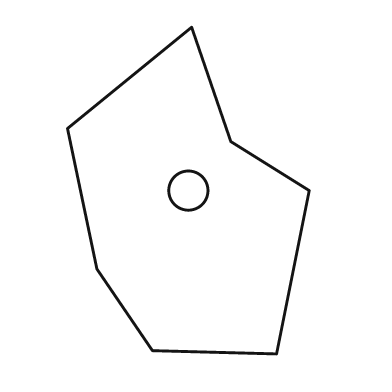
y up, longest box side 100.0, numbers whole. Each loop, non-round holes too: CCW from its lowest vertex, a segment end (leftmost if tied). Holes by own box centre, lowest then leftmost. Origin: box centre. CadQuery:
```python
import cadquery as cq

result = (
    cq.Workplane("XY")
    .moveTo(27.0, -50.0)
    .lineTo(37.0, 0.0)
    .lineTo(13.0, 15.0)
    .lineTo(1.0, 50.0)
    .lineTo(-37.0, 19.0)
    .lineTo(-28.0, -24.0)
    .lineTo(-11.0, -49.0)
    .close()
    .moveTo(0.0, 0.0)
    .circle(6.0)
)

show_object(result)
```